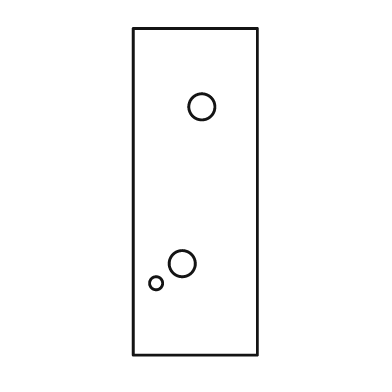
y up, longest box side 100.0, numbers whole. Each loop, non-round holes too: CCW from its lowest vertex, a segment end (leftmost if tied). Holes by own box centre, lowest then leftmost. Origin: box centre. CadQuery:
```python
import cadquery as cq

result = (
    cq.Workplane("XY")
    .moveTo(-19.0, -50.0)
    .lineTo(19.0, -50.0)
    .lineTo(19.0, 50.0)
    .lineTo(-19.0, 50.0)
    .close()
    .moveTo(-12.0, -28.0)
    .circle(2.0)
    .moveTo(-4.0, -22.0)
    .circle(4.0)
    .moveTo(2.0, 26.0)
    .circle(4.0)
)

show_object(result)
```